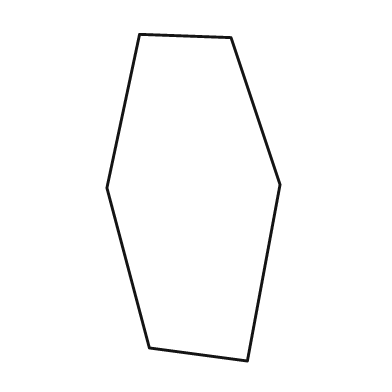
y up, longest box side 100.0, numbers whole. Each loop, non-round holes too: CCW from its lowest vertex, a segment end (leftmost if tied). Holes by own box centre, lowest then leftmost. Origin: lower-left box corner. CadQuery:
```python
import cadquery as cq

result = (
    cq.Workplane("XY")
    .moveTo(43.0, 0.0)
    .lineTo(53.0, 54.0)
    .lineTo(38.0, 99.0)
    .lineTo(10.0, 100.0)
    .lineTo(0.0, 53.0)
    .lineTo(13.0, 4.0)
    .close()
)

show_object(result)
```